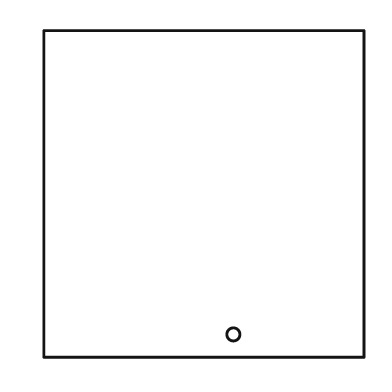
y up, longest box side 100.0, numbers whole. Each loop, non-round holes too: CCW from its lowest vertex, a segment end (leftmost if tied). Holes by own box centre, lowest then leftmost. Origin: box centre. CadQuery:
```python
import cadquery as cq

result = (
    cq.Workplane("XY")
    .moveTo(-49.0, -50.0)
    .lineTo(49.0, -50.0)
    .lineTo(49.0, 50.0)
    .lineTo(-49.0, 50.0)
    .close()
    .moveTo(9.0, -43.0)
    .circle(2.0)
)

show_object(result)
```